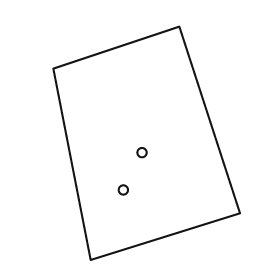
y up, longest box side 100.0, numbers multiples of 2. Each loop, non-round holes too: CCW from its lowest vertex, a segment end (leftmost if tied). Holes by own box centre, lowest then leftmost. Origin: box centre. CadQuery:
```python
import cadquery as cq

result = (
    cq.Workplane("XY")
    .moveTo(-24.0, -50.0)
    .lineTo(40.0, -30.0)
    .lineTo(14.0, 50.0)
    .lineTo(-40.0, 32.0)
    .close()
    .moveTo(-10.0, -20.0)
    .circle(2.0)
    .moveTo(-2.0, -4.0)
    .circle(2.0)
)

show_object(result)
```